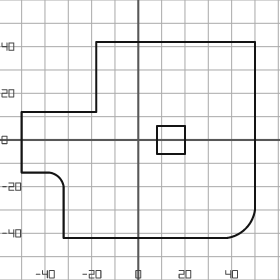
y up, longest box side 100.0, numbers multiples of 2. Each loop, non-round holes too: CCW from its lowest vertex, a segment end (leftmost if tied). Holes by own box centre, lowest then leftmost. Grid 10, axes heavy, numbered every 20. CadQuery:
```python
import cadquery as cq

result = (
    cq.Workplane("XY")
    .moveTo(-32.0, -42.0)
    .lineTo(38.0, -42.0)
    .threePointArc((46.0, -38.0), (50.0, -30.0))
    .lineTo(50.0, 42.0)
    .lineTo(-18.0, 42.0)
    .lineTo(-18.0, 12.0)
    .lineTo(-50.0, 12.0)
    .lineTo(-50.0, -14.0)
    .lineTo(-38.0, -14.0)
    .threePointArc((-34.0, -16.0), (-32.0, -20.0))
    .close()
    .moveTo(8.0, -6.0)
    .lineTo(20.0, -6.0)
    .lineTo(20.0, 6.0)
    .lineTo(8.0, 6.0)
    .close()
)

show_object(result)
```